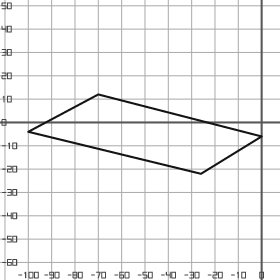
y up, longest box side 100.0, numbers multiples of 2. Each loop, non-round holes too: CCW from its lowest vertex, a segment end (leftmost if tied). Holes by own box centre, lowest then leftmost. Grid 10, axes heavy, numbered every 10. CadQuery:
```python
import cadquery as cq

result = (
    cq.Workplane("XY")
    .moveTo(-26.0, -22.0)
    .lineTo(0.0, -6.0)
    .lineTo(-70.0, 12.0)
    .lineTo(-100.0, -4.0)
    .close()
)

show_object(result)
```